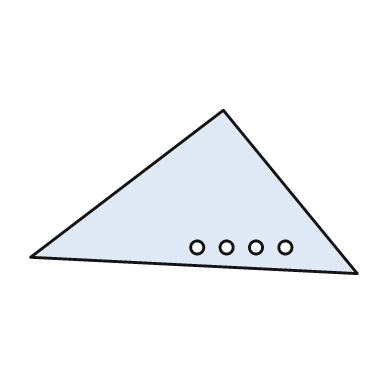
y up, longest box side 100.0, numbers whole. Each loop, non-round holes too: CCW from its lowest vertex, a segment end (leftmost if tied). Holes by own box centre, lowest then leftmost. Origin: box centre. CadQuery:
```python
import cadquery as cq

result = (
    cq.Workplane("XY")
    .moveTo(50.0, -25.0)
    .lineTo(9.0, 25.0)
    .lineTo(-50.0, -20.0)
    .close()
    .moveTo(1.0, -17.0)
    .circle(2.0)
    .moveTo(10.0, -17.0)
    .circle(2.0)
    .moveTo(19.0, -17.0)
    .circle(2.0)
    .moveTo(28.0, -17.0)
    .circle(2.0)
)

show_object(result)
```